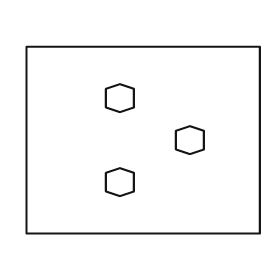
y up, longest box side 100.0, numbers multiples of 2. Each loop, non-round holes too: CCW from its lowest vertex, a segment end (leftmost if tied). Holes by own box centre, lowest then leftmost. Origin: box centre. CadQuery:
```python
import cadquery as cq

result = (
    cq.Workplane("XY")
    .moveTo(-50.0, -40.0)
    .lineTo(50.0, -40.0)
    .lineTo(50.0, 40.0)
    .lineTo(-50.0, 40.0)
    .close()
    .moveTo(-10.0, -24.0)
    .lineTo(-4.0, -22.0)
    .lineTo(-4.0, -14.0)
    .lineTo(-10.0, -12.0)
    .lineTo(-16.0, -14.0)
    .lineTo(-16.0, -22.0)
    .close()
    .moveTo(20.0, -6.0)
    .lineTo(26.0, -4.0)
    .lineTo(26.0, 4.0)
    .lineTo(20.0, 6.0)
    .lineTo(14.0, 4.0)
    .lineTo(14.0, -4.0)
    .close()
    .moveTo(-10.0, 12.0)
    .lineTo(-4.0, 14.0)
    .lineTo(-4.0, 22.0)
    .lineTo(-10.0, 24.0)
    .lineTo(-16.0, 22.0)
    .lineTo(-16.0, 14.0)
    .close()
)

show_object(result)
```